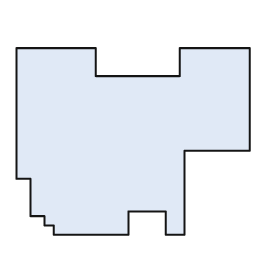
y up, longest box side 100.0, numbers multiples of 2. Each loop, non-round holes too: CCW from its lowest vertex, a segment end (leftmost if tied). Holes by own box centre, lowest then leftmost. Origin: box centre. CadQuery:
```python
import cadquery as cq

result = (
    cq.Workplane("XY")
    .moveTo(-34.0, -40.0)
    .lineTo(-2.0, -40.0)
    .lineTo(-2.0, -30.0)
    .lineTo(14.0, -30.0)
    .lineTo(14.0, -40.0)
    .lineTo(22.0, -40.0)
    .lineTo(22.0, -4.0)
    .lineTo(50.0, -4.0)
    .lineTo(50.0, 40.0)
    .lineTo(20.0, 40.0)
    .lineTo(20.0, 28.0)
    .lineTo(-16.0, 28.0)
    .lineTo(-16.0, 40.0)
    .lineTo(-50.0, 40.0)
    .lineTo(-50.0, -16.0)
    .lineTo(-44.0, -16.0)
    .lineTo(-44.0, -32.0)
    .lineTo(-38.0, -32.0)
    .lineTo(-38.0, -36.0)
    .lineTo(-34.0, -36.0)
    .close()
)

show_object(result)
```